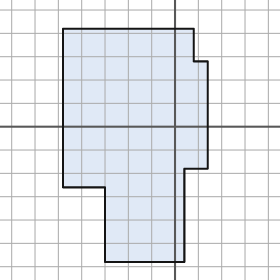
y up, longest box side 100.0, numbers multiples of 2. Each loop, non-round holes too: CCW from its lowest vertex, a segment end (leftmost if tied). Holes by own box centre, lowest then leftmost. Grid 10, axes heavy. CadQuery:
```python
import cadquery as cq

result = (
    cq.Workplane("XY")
    .moveTo(-30.0, -58.0)
    .lineTo(4.0, -58.0)
    .lineTo(4.0, -18.0)
    .lineTo(14.0, -18.0)
    .lineTo(14.0, 28.0)
    .lineTo(8.0, 28.0)
    .lineTo(8.0, 42.0)
    .lineTo(-48.0, 42.0)
    .lineTo(-48.0, -26.0)
    .lineTo(-30.0, -26.0)
    .close()
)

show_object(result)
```